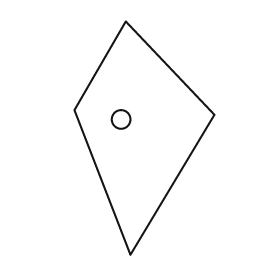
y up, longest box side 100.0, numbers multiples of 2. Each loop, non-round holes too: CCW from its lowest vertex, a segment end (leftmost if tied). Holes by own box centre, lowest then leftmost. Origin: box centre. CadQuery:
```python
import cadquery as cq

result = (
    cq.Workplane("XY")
    .moveTo(-6.0, -50.0)
    .lineTo(30.0, 10.0)
    .lineTo(-8.0, 50.0)
    .lineTo(-30.0, 12.0)
    .close()
    .moveTo(-10.0, 8.0)
    .circle(4.0)
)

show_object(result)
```